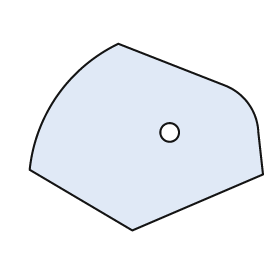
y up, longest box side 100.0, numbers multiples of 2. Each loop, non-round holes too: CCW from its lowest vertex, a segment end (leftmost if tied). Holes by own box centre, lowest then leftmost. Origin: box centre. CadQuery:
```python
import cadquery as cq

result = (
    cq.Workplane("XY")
    .moveTo(-6.0, -40.0)
    .lineTo(50.0, -16.0)
    .lineTo(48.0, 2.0)
    .threePointArc((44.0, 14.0), (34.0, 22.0))
    .lineTo(-12.0, 40.0)
    .threePointArc((-38.0, 18.0), (-50.0, -14.0))
    .close()
    .moveTo(10.0, 2.0)
    .circle(4.0)
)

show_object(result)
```